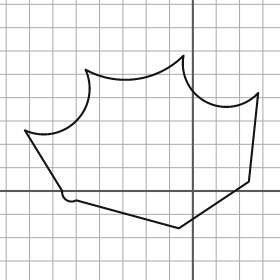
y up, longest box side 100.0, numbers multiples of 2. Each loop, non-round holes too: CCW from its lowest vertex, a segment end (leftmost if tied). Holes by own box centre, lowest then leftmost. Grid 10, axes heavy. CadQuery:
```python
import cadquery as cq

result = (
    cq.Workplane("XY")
    .moveTo(-6.0, -16.0)
    .lineTo(24.0, 4.0)
    .lineTo(28.0, 42.0)
    .threePointArc((6.0, 38.0), (-4.0, 58.0))
    .threePointArc((-24.0, 48.0), (-46.0, 52.0))
    .threePointArc((-50.0, 30.0), (-72.0, 26.0))
    .lineTo(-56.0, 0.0)
    .threePointArc((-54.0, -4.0), (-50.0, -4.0))
    .close()
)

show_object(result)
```